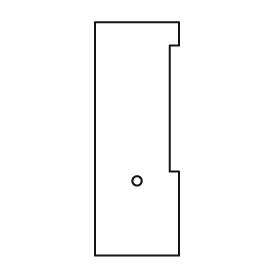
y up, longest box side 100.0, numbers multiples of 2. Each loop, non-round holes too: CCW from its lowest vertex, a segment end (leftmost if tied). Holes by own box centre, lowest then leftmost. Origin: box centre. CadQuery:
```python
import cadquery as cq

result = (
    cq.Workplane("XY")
    .moveTo(-18.0, -50.0)
    .lineTo(18.0, -50.0)
    .lineTo(18.0, -14.0)
    .lineTo(14.0, -14.0)
    .lineTo(14.0, 40.0)
    .lineTo(18.0, 40.0)
    .lineTo(18.0, 50.0)
    .lineTo(-18.0, 50.0)
    .close()
    .moveTo(0.0, -18.0)
    .circle(2.0)
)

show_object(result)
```